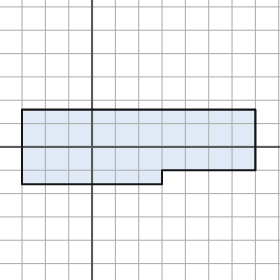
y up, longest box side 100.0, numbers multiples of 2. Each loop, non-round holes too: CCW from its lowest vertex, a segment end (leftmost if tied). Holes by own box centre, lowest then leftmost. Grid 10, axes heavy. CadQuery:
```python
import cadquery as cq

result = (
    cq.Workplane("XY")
    .moveTo(-30.0, -16.0)
    .lineTo(30.0, -16.0)
    .lineTo(30.0, -10.0)
    .lineTo(70.0, -10.0)
    .lineTo(70.0, 16.0)
    .lineTo(-30.0, 16.0)
    .close()
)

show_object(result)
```